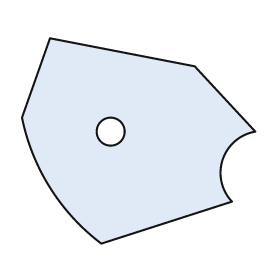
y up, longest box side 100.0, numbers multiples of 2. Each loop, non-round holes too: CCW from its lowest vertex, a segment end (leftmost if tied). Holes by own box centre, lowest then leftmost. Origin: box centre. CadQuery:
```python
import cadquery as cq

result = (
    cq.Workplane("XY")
    .moveTo(-16.0, -44.0)
    .lineTo(40.0, -26.0)
    .threePointArc((36.0, -8.0), (50.0, 4.0))
    .lineTo(24.0, 32.0)
    .lineTo(-38.0, 44.0)
    .lineTo(-50.0, 10.0)
    .threePointArc((-38.0, -20.0), (-16.0, -44.0))
    .close()
    .moveTo(-12.0, 4.0)
    .circle(6.0)
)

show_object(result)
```